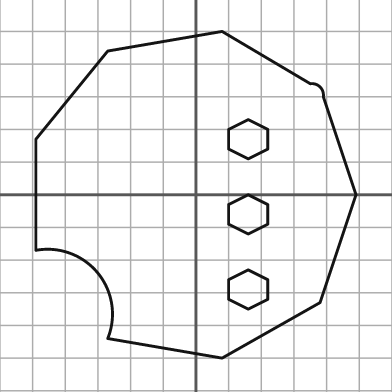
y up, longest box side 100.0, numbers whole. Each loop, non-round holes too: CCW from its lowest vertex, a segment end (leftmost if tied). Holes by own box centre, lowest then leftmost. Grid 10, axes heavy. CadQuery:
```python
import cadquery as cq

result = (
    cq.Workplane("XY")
    .moveTo(8.0, -50.0)
    .lineTo(38.0, -33.0)
    .lineTo(49.0, 0.0)
    .lineTo(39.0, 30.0)
    .threePointArc((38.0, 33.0), (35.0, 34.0))
    .lineTo(8.0, 50.0)
    .lineTo(-27.0, 44.0)
    .lineTo(-49.0, 17.0)
    .lineTo(-49.0, -17.0)
    .threePointArc((-30.0, -24.0), (-27.0, -44.0))
    .close()
    .moveTo(16.0, -35.0)
    .lineTo(22.0, -32.0)
    .lineTo(22.0, -26.0)
    .lineTo(16.0, -23.0)
    .lineTo(10.0, -26.0)
    .lineTo(10.0, -32.0)
    .close()
    .moveTo(16.0, -12.0)
    .lineTo(22.0, -9.0)
    .lineTo(22.0, -3.0)
    .lineTo(16.0, 0.0)
    .lineTo(10.0, -3.0)
    .lineTo(10.0, -9.0)
    .close()
    .moveTo(16.0, 11.0)
    .lineTo(22.0, 14.0)
    .lineTo(22.0, 20.0)
    .lineTo(16.0, 23.0)
    .lineTo(10.0, 20.0)
    .lineTo(10.0, 14.0)
    .close()
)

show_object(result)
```